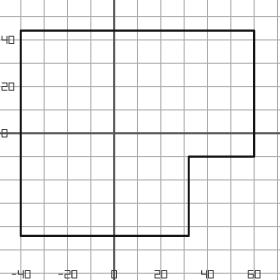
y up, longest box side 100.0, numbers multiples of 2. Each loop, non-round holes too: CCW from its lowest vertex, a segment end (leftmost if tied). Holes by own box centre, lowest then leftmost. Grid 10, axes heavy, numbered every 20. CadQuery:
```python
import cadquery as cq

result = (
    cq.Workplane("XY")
    .moveTo(-40.0, -44.0)
    .lineTo(32.0, -44.0)
    .lineTo(32.0, -10.0)
    .lineTo(60.0, -10.0)
    .lineTo(60.0, 44.0)
    .lineTo(-40.0, 44.0)
    .close()
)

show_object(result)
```